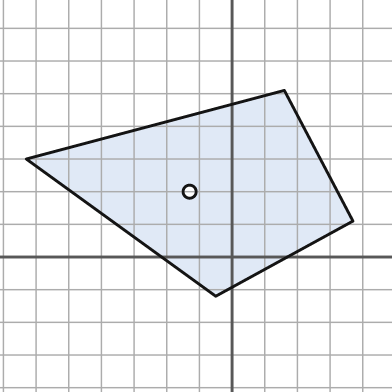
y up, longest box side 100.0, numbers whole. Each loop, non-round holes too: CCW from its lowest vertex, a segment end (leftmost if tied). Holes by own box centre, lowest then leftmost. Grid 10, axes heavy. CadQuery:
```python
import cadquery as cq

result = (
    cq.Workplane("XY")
    .moveTo(-5.0, -12.0)
    .lineTo(37.0, 11.0)
    .lineTo(16.0, 51.0)
    .lineTo(-63.0, 30.0)
    .close()
    .moveTo(-13.0, 20.0)
    .circle(2.0)
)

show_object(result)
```